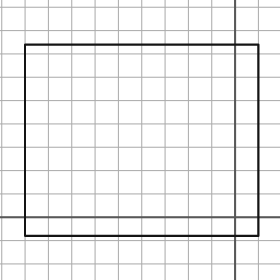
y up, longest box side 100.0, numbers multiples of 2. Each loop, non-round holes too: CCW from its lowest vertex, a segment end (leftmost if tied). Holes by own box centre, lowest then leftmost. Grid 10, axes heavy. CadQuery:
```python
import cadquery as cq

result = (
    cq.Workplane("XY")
    .moveTo(-90.0, -8.0)
    .lineTo(10.0, -8.0)
    .lineTo(10.0, 74.0)
    .lineTo(-90.0, 74.0)
    .close()
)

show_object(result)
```